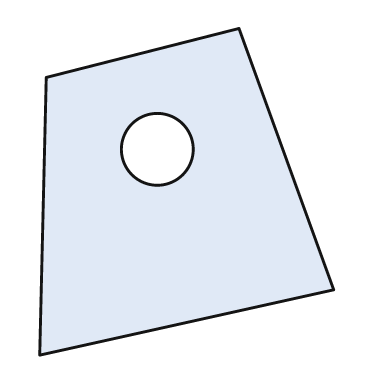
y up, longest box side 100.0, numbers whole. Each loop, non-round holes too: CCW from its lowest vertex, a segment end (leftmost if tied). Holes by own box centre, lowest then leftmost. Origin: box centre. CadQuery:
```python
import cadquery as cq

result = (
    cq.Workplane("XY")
    .moveTo(-45.0, -50.0)
    .lineTo(45.0, -30.0)
    .lineTo(16.0, 50.0)
    .lineTo(-43.0, 35.0)
    .close()
    .moveTo(-9.0, 13.0)
    .circle(11.0)
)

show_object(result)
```